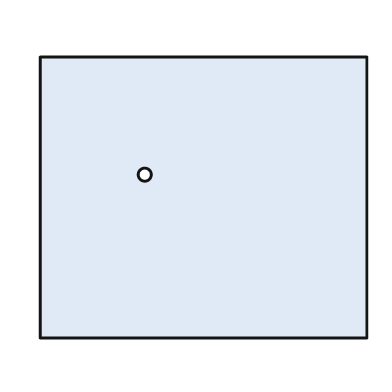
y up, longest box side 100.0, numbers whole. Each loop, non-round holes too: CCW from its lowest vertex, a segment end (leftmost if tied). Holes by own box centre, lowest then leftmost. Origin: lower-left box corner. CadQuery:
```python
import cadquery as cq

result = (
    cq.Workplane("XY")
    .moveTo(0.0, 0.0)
    .lineTo(100.0, 0.0)
    .lineTo(100.0, 86.0)
    .lineTo(0.0, 86.0)
    .close()
    .moveTo(32.0, 50.0)
    .circle(2.0)
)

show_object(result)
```